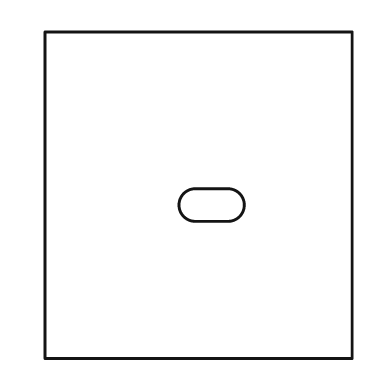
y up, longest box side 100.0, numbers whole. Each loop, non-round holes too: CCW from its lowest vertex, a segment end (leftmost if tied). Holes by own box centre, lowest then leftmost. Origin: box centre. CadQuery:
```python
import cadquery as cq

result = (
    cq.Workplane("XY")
    .moveTo(-47.0, -50.0)
    .lineTo(47.0, -50.0)
    .lineTo(47.0, 50.0)
    .lineTo(-47.0, 50.0)
    .close()
    .moveTo(-1.0, -8.0)
    .lineTo(9.0, -8.0)
    .threePointArc((14.0, -3.0), (9.0, 2.0))
    .lineTo(-1.0, 2.0)
    .threePointArc((-6.0, -3.0), (-1.0, -8.0))
    .close()
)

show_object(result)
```